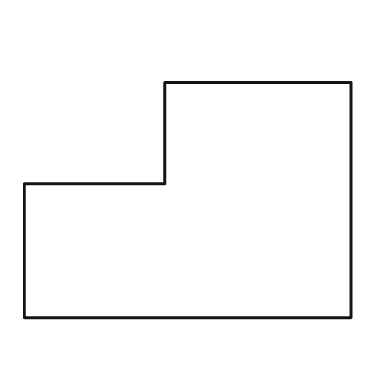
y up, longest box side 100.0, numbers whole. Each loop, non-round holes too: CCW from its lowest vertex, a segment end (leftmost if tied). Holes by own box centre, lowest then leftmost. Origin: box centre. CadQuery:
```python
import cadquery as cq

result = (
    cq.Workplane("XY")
    .moveTo(-50.0, -36.0)
    .lineTo(50.0, -36.0)
    .lineTo(50.0, 36.0)
    .lineTo(-7.0, 36.0)
    .lineTo(-7.0, 5.0)
    .lineTo(-50.0, 5.0)
    .close()
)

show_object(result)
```